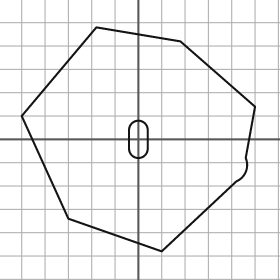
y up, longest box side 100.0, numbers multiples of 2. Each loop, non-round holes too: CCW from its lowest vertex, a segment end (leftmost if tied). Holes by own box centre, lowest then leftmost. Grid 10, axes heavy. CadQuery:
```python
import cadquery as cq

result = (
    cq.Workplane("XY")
    .moveTo(10.0, -48.0)
    .lineTo(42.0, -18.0)
    .threePointArc((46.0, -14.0), (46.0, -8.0))
    .lineTo(50.0, 14.0)
    .lineTo(18.0, 42.0)
    .lineTo(-18.0, 48.0)
    .lineTo(-50.0, 10.0)
    .lineTo(-30.0, -34.0)
    .close()
    .moveTo(-4.0, -4.0)
    .threePointArc((0.0, -8.0), (4.0, -4.0))
    .lineTo(4.0, 4.0)
    .threePointArc((0.0, 8.0), (-4.0, 4.0))
    .close()
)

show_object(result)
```